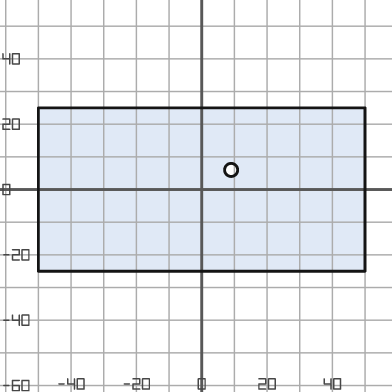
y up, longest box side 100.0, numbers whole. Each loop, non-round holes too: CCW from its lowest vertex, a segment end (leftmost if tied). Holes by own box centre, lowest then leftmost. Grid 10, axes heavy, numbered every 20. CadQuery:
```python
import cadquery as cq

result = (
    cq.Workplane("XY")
    .moveTo(-50.0, -25.0)
    .lineTo(50.0, -25.0)
    .lineTo(50.0, 25.0)
    .lineTo(-50.0, 25.0)
    .close()
    .moveTo(9.0, 6.0)
    .circle(2.0)
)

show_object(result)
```